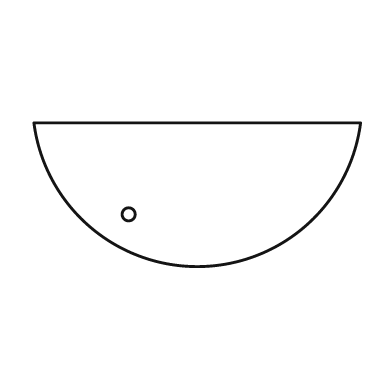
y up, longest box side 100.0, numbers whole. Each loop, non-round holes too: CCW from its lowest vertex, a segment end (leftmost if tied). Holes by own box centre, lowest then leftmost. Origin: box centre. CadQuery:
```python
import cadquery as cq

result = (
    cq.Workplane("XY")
    .moveTo(-50.0, 22.0)
    .threePointArc((0.0, -22.0), (50.0, 22.0))
    .close()
    .moveTo(-21.0, -6.0)
    .circle(2.0)
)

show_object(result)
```